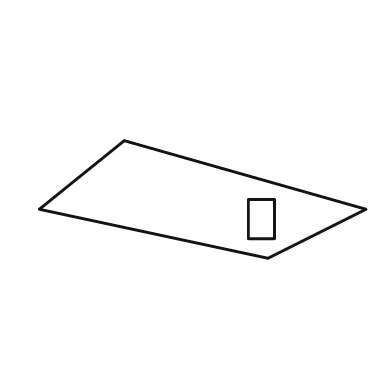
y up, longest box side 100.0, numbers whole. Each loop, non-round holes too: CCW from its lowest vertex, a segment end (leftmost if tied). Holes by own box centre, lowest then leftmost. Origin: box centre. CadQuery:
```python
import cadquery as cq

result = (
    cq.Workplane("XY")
    .moveTo(20.0, -18.0)
    .lineTo(50.0, -3.0)
    .lineTo(-24.0, 18.0)
    .lineTo(-50.0, -3.0)
    .close()
    .moveTo(14.0, -12.0)
    .lineTo(22.0, -12.0)
    .lineTo(22.0, 0.0)
    .lineTo(14.0, 0.0)
    .close()
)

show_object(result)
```